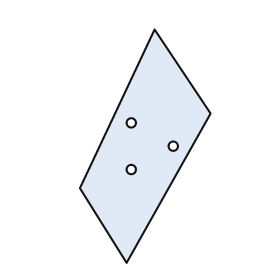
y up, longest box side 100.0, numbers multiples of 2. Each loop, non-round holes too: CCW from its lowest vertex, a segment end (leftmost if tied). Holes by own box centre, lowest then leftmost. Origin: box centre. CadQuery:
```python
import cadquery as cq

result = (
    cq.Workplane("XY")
    .moveTo(-8.0, -50.0)
    .lineTo(28.0, 14.0)
    .lineTo(4.0, 50.0)
    .lineTo(-28.0, -18.0)
    .close()
    .moveTo(-6.0, -10.0)
    .circle(2.0)
    .moveTo(12.0, 0.0)
    .circle(2.0)
    .moveTo(-6.0, 10.0)
    .circle(2.0)
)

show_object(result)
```